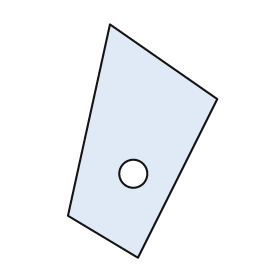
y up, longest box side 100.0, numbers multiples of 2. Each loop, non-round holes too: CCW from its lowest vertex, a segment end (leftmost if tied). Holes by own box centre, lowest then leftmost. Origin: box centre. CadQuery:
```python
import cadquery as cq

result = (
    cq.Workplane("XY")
    .moveTo(-2.0, -50.0)
    .lineTo(32.0, 18.0)
    .lineTo(-14.0, 50.0)
    .lineTo(-32.0, -32.0)
    .close()
    .moveTo(-4.0, -14.0)
    .circle(6.0)
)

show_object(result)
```